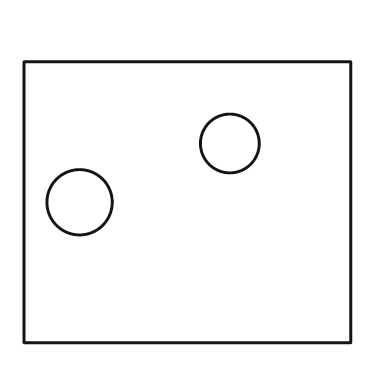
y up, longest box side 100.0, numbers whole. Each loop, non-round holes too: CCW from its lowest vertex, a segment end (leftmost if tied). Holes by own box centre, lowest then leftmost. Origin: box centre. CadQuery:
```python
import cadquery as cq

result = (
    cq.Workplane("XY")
    .moveTo(-50.0, -43.0)
    .lineTo(50.0, -43.0)
    .lineTo(50.0, 43.0)
    .lineTo(-50.0, 43.0)
    .close()
    .moveTo(-33.0, 0.0)
    .circle(10.0)
    .moveTo(13.0, 18.0)
    .circle(9.0)
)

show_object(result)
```